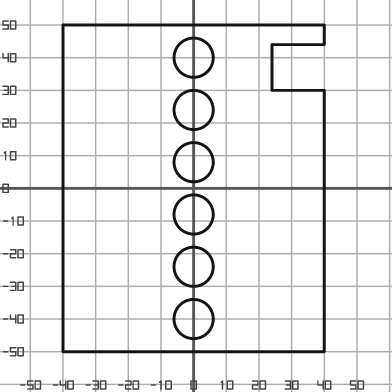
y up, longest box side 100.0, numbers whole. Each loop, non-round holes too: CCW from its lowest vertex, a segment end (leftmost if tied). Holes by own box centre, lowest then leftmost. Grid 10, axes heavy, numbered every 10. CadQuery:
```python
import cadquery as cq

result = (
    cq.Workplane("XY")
    .moveTo(-40.0, -50.0)
    .lineTo(40.0, -50.0)
    .lineTo(40.0, 30.0)
    .lineTo(24.0, 30.0)
    .lineTo(24.0, 44.0)
    .lineTo(40.0, 44.0)
    .lineTo(40.0, 50.0)
    .lineTo(-40.0, 50.0)
    .close()
    .moveTo(0.0, -40.0)
    .circle(6.0)
    .moveTo(0.0, -24.0)
    .circle(6.0)
    .moveTo(0.0, -8.0)
    .circle(6.0)
    .moveTo(0.0, 8.0)
    .circle(6.0)
    .moveTo(0.0, 24.0)
    .circle(6.0)
    .moveTo(0.0, 40.0)
    .circle(6.0)
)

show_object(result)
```